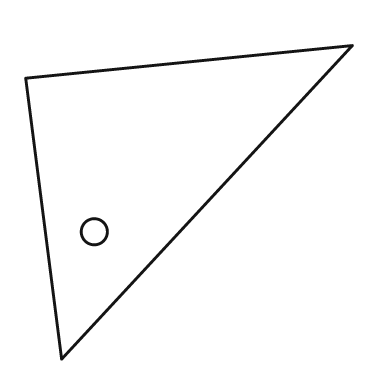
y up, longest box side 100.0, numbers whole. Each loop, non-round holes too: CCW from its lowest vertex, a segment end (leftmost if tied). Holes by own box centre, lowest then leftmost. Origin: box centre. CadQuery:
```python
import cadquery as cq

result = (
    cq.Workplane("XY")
    .moveTo(-39.0, -48.0)
    .lineTo(50.0, 48.0)
    .lineTo(-50.0, 38.0)
    .close()
    .moveTo(-29.0, -9.0)
    .circle(4.0)
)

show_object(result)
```